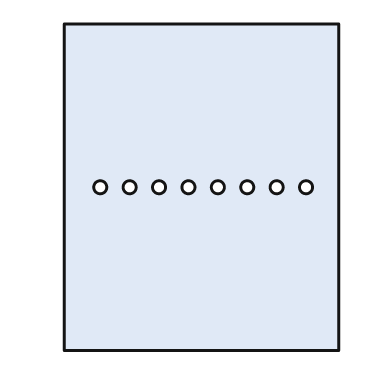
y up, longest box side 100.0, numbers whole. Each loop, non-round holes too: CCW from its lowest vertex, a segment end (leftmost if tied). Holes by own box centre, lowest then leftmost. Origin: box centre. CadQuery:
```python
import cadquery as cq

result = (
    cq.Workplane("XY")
    .moveTo(-42.0, -50.0)
    .lineTo(42.0, -50.0)
    .lineTo(42.0, 50.0)
    .lineTo(-42.0, 50.0)
    .close()
    .moveTo(-31.0, 0.0)
    .circle(2.0)
    .moveTo(-22.0, 0.0)
    .circle(2.0)
    .moveTo(-13.0, 0.0)
    .circle(2.0)
    .moveTo(-4.0, 0.0)
    .circle(2.0)
    .moveTo(5.0, 0.0)
    .circle(2.0)
    .moveTo(14.0, 0.0)
    .circle(2.0)
    .moveTo(23.0, 0.0)
    .circle(2.0)
    .moveTo(32.0, 0.0)
    .circle(2.0)
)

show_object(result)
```